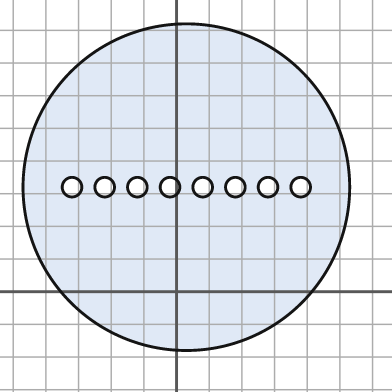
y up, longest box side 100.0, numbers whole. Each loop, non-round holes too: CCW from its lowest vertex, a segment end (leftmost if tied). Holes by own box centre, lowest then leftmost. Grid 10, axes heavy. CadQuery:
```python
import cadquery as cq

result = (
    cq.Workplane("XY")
    .moveTo(3.0, 32.0)
    .circle(50.0)
    .moveTo(-32.0, 32.0)
    .circle(3.0)
    .moveTo(-22.0, 32.0)
    .circle(3.0)
    .moveTo(-12.0, 32.0)
    .circle(3.0)
    .moveTo(-2.0, 32.0)
    .circle(3.0)
    .moveTo(8.0, 32.0)
    .circle(3.0)
    .moveTo(18.0, 32.0)
    .circle(3.0)
    .moveTo(28.0, 32.0)
    .circle(3.0)
    .moveTo(38.0, 32.0)
    .circle(3.0)
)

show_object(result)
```